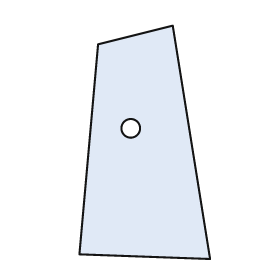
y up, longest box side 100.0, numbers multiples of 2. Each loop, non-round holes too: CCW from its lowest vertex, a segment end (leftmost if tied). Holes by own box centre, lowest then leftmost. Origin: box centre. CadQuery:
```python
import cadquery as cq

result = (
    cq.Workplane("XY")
    .moveTo(28.0, -50.0)
    .lineTo(12.0, 50.0)
    .lineTo(-20.0, 42.0)
    .lineTo(-28.0, -48.0)
    .close()
    .moveTo(-6.0, 6.0)
    .circle(4.0)
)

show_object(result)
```